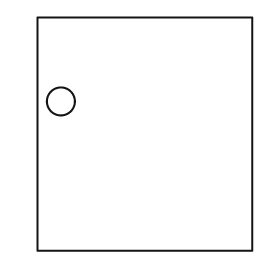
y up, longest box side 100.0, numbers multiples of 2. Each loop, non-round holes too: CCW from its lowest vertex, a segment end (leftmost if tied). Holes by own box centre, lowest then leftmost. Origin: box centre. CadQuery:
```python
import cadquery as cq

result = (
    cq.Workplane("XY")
    .moveTo(-46.0, -50.0)
    .lineTo(46.0, -50.0)
    .lineTo(46.0, 50.0)
    .lineTo(-46.0, 50.0)
    .close()
    .moveTo(-36.0, 14.0)
    .circle(6.0)
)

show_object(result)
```